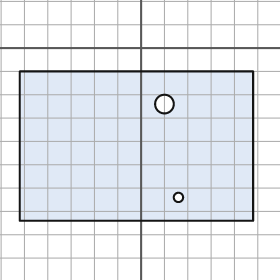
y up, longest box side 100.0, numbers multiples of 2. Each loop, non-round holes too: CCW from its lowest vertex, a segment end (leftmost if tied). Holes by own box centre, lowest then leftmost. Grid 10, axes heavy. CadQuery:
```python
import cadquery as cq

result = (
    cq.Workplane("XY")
    .moveTo(-52.0, -74.0)
    .lineTo(48.0, -74.0)
    .lineTo(48.0, -10.0)
    .lineTo(-52.0, -10.0)
    .close()
    .moveTo(16.0, -64.0)
    .circle(2.0)
    .moveTo(10.0, -24.0)
    .circle(4.0)
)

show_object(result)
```